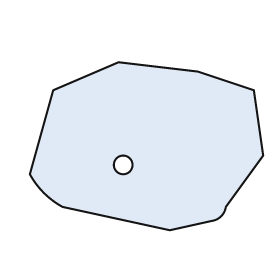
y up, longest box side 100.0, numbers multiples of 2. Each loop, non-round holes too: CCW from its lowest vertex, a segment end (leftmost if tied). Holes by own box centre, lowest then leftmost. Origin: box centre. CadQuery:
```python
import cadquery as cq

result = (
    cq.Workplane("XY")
    .moveTo(10.0, -36.0)
    .lineTo(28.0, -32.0)
    .threePointArc((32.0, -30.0), (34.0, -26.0))
    .lineTo(50.0, -4.0)
    .lineTo(46.0, 24.0)
    .lineTo(22.0, 32.0)
    .lineTo(-12.0, 36.0)
    .lineTo(-40.0, 24.0)
    .lineTo(-50.0, -12.0)
    .threePointArc((-44.0, -20.0), (-36.0, -26.0))
    .close()
    .moveTo(-10.0, -8.0)
    .circle(4.0)
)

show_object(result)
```